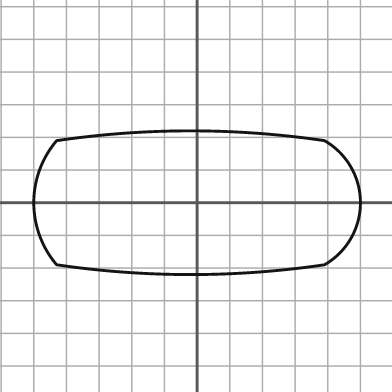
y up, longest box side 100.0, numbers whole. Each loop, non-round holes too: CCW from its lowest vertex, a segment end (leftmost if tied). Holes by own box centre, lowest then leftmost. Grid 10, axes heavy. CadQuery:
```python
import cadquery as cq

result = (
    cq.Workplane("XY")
    .moveTo(-43.0, -19.0)
    .threePointArc((-2.0, -22.0), (39.0, -19.0))
    .threePointArc((50.0, 0.0), (39.0, 19.0))
    .threePointArc((-2.0, 22.0), (-43.0, 19.0))
    .threePointArc((-50.0, 0.0), (-43.0, -19.0))
    .close()
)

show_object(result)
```